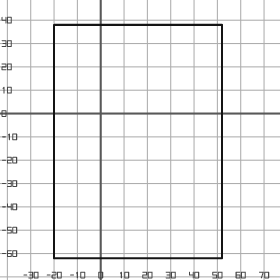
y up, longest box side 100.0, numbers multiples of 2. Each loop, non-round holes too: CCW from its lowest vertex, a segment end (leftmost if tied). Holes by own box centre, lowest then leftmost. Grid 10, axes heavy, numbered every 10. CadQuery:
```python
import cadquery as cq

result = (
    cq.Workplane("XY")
    .moveTo(-20.0, -62.0)
    .lineTo(52.0, -62.0)
    .lineTo(52.0, 38.0)
    .lineTo(-20.0, 38.0)
    .close()
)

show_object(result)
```